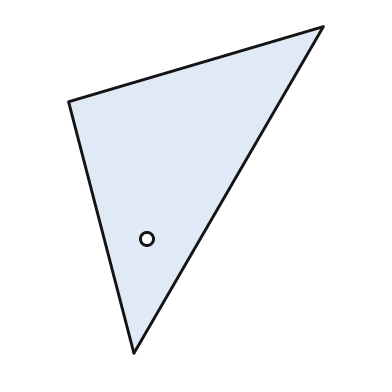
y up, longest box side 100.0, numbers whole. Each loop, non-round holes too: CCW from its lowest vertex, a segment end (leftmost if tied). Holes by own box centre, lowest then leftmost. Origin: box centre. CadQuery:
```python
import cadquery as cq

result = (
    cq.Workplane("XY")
    .moveTo(-19.0, -50.0)
    .lineTo(39.0, 50.0)
    .lineTo(-39.0, 27.0)
    .close()
    .moveTo(-15.0, -15.0)
    .circle(2.0)
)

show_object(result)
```